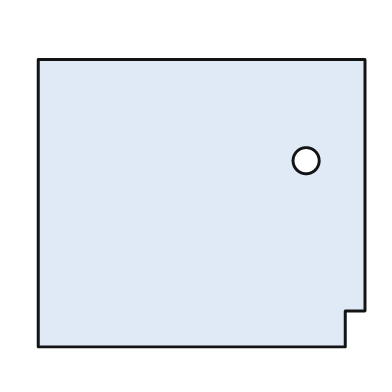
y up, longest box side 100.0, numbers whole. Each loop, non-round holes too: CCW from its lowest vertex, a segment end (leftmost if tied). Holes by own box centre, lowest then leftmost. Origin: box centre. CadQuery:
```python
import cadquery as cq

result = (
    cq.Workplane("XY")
    .moveTo(-50.0, -44.0)
    .lineTo(44.0, -44.0)
    .lineTo(44.0, -33.0)
    .lineTo(50.0, -33.0)
    .lineTo(50.0, 44.0)
    .lineTo(-50.0, 44.0)
    .close()
    .moveTo(32.0, 13.0)
    .circle(4.0)
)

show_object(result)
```